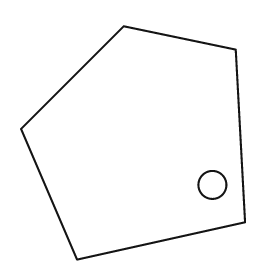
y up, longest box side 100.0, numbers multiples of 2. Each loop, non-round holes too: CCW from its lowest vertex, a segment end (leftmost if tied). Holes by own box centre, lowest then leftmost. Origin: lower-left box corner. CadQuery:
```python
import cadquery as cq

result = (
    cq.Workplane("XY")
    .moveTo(24.0, 0.0)
    .lineTo(96.0, 16.0)
    .lineTo(92.0, 90.0)
    .lineTo(44.0, 100.0)
    .lineTo(0.0, 56.0)
    .close()
    .moveTo(82.0, 32.0)
    .circle(6.0)
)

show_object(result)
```